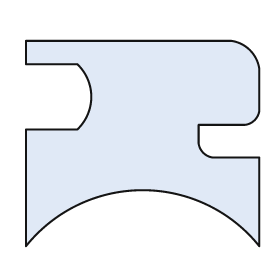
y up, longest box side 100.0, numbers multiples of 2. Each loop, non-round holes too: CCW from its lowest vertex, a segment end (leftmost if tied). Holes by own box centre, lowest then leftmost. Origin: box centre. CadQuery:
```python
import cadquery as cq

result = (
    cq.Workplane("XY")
    .moveTo(-50.0, -44.0)
    .threePointArc((0.0, -20.0), (50.0, -44.0))
    .lineTo(50.0, -6.0)
    .lineTo(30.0, -6.0)
    .threePointArc((26.0, -4.0), (24.0, 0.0))
    .lineTo(24.0, 8.0)
    .lineTo(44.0, 8.0)
    .threePointArc((48.0, 10.0), (50.0, 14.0))
    .lineTo(50.0, 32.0)
    .threePointArc((46.0, 40.0), (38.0, 44.0))
    .lineTo(-50.0, 44.0)
    .lineTo(-50.0, 34.0)
    .lineTo(-28.0, 34.0)
    .threePointArc((-22.0, 20.0), (-28.0, 6.0))
    .lineTo(-50.0, 6.0)
    .close()
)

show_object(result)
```